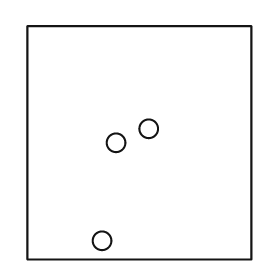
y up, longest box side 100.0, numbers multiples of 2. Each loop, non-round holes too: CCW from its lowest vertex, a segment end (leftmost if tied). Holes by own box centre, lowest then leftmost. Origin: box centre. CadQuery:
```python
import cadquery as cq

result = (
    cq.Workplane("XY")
    .moveTo(-48.0, -50.0)
    .lineTo(48.0, -50.0)
    .lineTo(48.0, 50.0)
    .lineTo(-48.0, 50.0)
    .close()
    .moveTo(-16.0, -42.0)
    .circle(4.0)
    .moveTo(-10.0, 0.0)
    .circle(4.0)
    .moveTo(4.0, 6.0)
    .circle(4.0)
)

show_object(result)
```